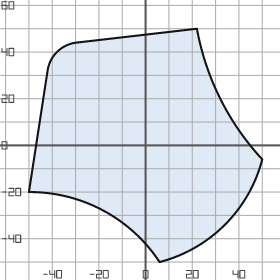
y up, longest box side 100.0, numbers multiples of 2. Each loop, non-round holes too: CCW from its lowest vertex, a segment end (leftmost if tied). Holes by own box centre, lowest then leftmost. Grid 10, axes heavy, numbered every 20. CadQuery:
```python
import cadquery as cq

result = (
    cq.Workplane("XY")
    .moveTo(6.0, -50.0)
    .threePointArc((34.0, -34.0), (50.0, -6.0))
    .threePointArc((32.0, 20.0), (22.0, 50.0))
    .lineTo(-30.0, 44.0)
    .threePointArc((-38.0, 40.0), (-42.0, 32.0))
    .lineTo(-50.0, -20.0)
    .threePointArc((-18.0, -28.0), (6.0, -50.0))
    .close()
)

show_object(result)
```